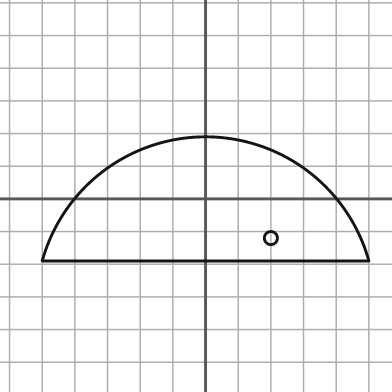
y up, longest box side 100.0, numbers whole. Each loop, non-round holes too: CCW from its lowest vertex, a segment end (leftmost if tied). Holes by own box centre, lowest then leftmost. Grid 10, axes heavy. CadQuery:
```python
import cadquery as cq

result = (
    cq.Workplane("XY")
    .moveTo(-50.0, -19.0)
    .lineTo(50.0, -19.0)
    .threePointArc((0.0, 19.0), (-50.0, -19.0))
    .close()
    .moveTo(20.0, -12.0)
    .circle(2.0)
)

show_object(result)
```